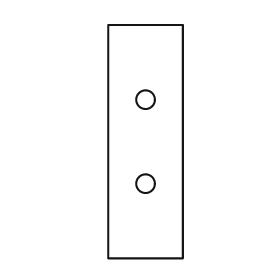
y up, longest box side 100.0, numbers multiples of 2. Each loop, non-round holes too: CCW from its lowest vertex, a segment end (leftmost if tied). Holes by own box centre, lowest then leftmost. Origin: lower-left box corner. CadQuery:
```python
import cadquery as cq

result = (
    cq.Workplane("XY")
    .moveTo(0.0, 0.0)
    .lineTo(32.0, 0.0)
    .lineTo(32.0, 100.0)
    .lineTo(0.0, 100.0)
    .close()
    .moveTo(16.0, 32.0)
    .circle(4.0)
    .moveTo(16.0, 68.0)
    .circle(4.0)
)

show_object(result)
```